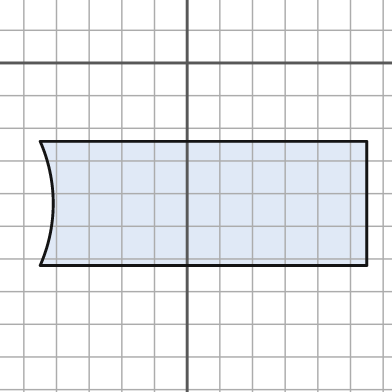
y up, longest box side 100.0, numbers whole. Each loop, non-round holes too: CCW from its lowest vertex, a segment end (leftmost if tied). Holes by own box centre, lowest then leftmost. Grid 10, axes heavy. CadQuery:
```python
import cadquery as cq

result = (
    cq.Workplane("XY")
    .moveTo(-45.0, -62.0)
    .lineTo(55.0, -62.0)
    .lineTo(55.0, -24.0)
    .lineTo(-45.0, -24.0)
    .threePointArc((-41.0, -43.0), (-45.0, -62.0))
    .close()
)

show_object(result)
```